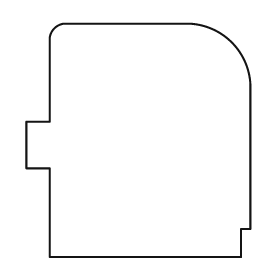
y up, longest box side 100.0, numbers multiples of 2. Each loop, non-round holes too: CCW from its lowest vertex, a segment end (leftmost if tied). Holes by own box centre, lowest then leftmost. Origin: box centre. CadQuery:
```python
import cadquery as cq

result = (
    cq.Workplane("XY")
    .moveTo(-38.0, -50.0)
    .lineTo(44.0, -50.0)
    .lineTo(44.0, -38.0)
    .lineTo(48.0, -38.0)
    .lineTo(48.0, 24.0)
    .threePointArc((40.0, 42.0), (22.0, 50.0))
    .lineTo(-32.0, 50.0)
    .threePointArc((-36.0, 48.0), (-38.0, 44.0))
    .lineTo(-38.0, 8.0)
    .lineTo(-48.0, 8.0)
    .lineTo(-48.0, -12.0)
    .lineTo(-38.0, -12.0)
    .close()
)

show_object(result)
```